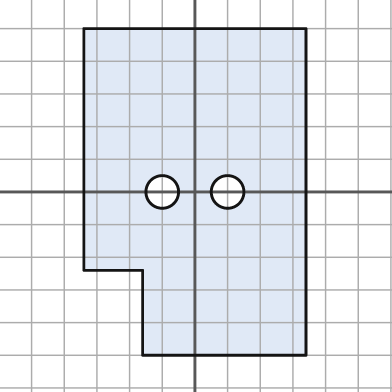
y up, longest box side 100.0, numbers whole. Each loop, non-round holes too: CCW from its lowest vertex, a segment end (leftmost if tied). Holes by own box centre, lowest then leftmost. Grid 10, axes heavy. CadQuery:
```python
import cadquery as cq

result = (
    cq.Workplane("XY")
    .moveTo(-16.0, -50.0)
    .lineTo(34.0, -50.0)
    .lineTo(34.0, 50.0)
    .lineTo(-34.0, 50.0)
    .lineTo(-34.0, -24.0)
    .lineTo(-16.0, -24.0)
    .close()
    .moveTo(-10.0, 0.0)
    .circle(5.0)
    .moveTo(10.0, 0.0)
    .circle(5.0)
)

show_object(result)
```